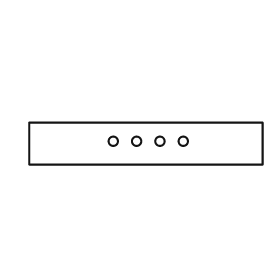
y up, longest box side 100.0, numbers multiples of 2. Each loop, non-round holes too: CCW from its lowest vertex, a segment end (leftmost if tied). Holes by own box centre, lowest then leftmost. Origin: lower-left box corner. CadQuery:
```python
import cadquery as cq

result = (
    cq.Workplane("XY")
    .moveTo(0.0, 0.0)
    .lineTo(100.0, 0.0)
    .lineTo(100.0, 18.0)
    .lineTo(0.0, 18.0)
    .close()
    .moveTo(36.0, 10.0)
    .circle(2.0)
    .moveTo(46.0, 10.0)
    .circle(2.0)
    .moveTo(56.0, 10.0)
    .circle(2.0)
    .moveTo(66.0, 10.0)
    .circle(2.0)
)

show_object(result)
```